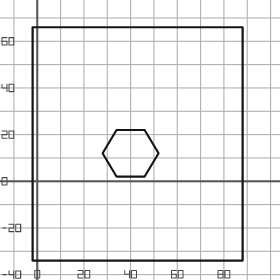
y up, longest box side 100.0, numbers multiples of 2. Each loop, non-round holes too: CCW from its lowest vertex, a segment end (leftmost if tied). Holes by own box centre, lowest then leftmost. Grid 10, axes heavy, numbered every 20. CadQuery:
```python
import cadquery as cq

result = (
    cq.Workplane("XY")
    .moveTo(-2.0, -34.0)
    .lineTo(88.0, -34.0)
    .lineTo(88.0, 66.0)
    .lineTo(-2.0, 66.0)
    .close()
    .moveTo(34.0, 2.0)
    .lineTo(46.0, 2.0)
    .lineTo(52.0, 12.0)
    .lineTo(46.0, 22.0)
    .lineTo(34.0, 22.0)
    .lineTo(28.0, 12.0)
    .close()
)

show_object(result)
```